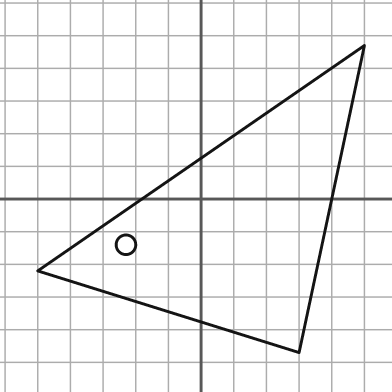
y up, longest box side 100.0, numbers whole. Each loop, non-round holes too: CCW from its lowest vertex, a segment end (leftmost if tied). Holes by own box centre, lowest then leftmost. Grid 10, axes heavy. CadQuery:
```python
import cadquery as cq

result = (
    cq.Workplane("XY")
    .moveTo(30.0, -47.0)
    .lineTo(50.0, 47.0)
    .lineTo(-50.0, -22.0)
    .close()
    .moveTo(-23.0, -14.0)
    .circle(3.0)
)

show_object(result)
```